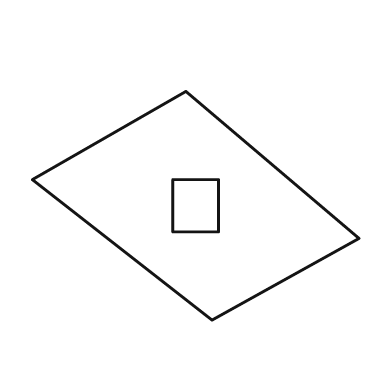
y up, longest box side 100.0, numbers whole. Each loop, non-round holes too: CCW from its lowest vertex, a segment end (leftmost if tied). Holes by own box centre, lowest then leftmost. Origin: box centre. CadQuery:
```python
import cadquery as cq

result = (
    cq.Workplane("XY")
    .moveTo(5.0, -35.0)
    .lineTo(50.0, -10.0)
    .lineTo(-3.0, 35.0)
    .lineTo(-50.0, 8.0)
    .close()
    .moveTo(-7.0, -8.0)
    .lineTo(7.0, -8.0)
    .lineTo(7.0, 8.0)
    .lineTo(-7.0, 8.0)
    .close()
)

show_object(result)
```